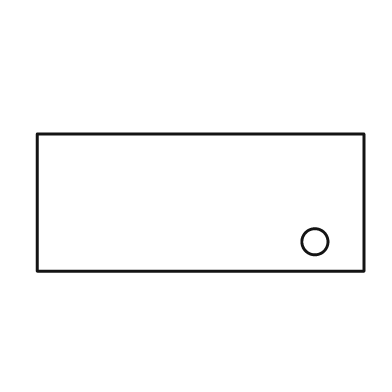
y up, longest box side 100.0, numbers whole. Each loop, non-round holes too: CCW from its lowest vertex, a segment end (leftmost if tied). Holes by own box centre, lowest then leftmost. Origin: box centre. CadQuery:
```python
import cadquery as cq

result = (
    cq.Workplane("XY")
    .moveTo(-50.0, -21.0)
    .lineTo(50.0, -21.0)
    .lineTo(50.0, 21.0)
    .lineTo(-50.0, 21.0)
    .close()
    .moveTo(35.0, -12.0)
    .circle(4.0)
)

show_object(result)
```